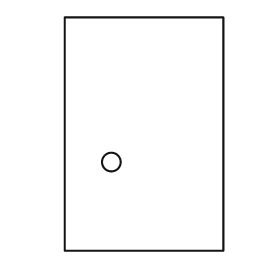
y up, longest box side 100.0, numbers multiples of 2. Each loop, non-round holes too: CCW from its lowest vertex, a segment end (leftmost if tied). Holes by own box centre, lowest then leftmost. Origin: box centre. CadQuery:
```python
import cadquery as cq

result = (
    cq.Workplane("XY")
    .moveTo(-34.0, -50.0)
    .lineTo(34.0, -50.0)
    .lineTo(34.0, 50.0)
    .lineTo(-34.0, 50.0)
    .close()
    .moveTo(-14.0, -12.0)
    .circle(4.0)
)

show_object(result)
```